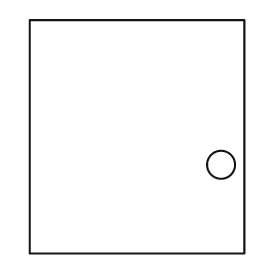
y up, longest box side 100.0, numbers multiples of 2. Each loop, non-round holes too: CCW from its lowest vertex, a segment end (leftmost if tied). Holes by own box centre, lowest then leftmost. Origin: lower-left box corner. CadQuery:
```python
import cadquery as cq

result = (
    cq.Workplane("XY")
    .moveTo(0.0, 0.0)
    .lineTo(92.0, 0.0)
    .lineTo(92.0, 100.0)
    .lineTo(0.0, 100.0)
    .close()
    .moveTo(82.0, 38.0)
    .circle(6.0)
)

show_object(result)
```